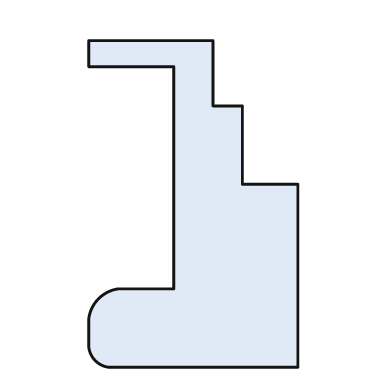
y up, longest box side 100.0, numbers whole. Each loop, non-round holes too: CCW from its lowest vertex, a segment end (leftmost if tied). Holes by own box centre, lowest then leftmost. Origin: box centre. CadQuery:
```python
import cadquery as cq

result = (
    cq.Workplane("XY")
    .moveTo(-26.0, -50.0)
    .lineTo(32.0, -50.0)
    .lineTo(32.0, 6.0)
    .lineTo(15.0, 6.0)
    .lineTo(15.0, 30.0)
    .lineTo(6.0, 30.0)
    .lineTo(6.0, 50.0)
    .lineTo(-32.0, 50.0)
    .lineTo(-32.0, 42.0)
    .lineTo(-6.0, 42.0)
    .lineTo(-6.0, -26.0)
    .lineTo(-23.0, -26.0)
    .threePointArc((-29.0, -29.0), (-32.0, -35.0))
    .lineTo(-32.0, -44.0)
    .threePointArc((-30.0, -48.0), (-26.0, -50.0))
    .close()
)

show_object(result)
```